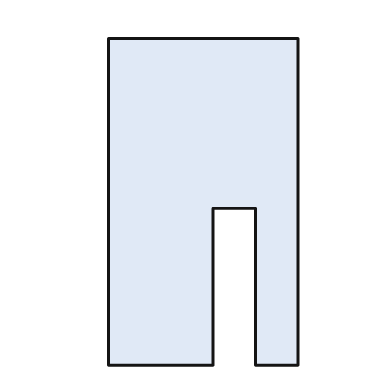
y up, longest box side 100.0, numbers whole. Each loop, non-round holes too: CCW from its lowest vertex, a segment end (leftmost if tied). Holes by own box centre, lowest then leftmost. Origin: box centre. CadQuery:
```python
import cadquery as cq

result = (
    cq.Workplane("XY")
    .moveTo(-29.0, -50.0)
    .lineTo(3.0, -50.0)
    .lineTo(3.0, -2.0)
    .lineTo(16.0, -2.0)
    .lineTo(16.0, -50.0)
    .lineTo(29.0, -50.0)
    .lineTo(29.0, 50.0)
    .lineTo(-29.0, 50.0)
    .close()
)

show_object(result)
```